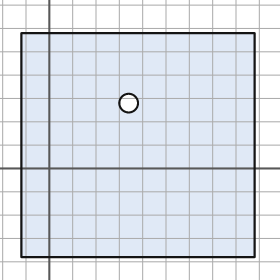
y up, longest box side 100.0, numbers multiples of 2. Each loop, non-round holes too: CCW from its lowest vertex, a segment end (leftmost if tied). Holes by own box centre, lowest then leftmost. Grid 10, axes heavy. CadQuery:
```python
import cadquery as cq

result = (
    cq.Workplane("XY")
    .moveTo(-12.0, -38.0)
    .lineTo(88.0, -38.0)
    .lineTo(88.0, 58.0)
    .lineTo(-12.0, 58.0)
    .close()
    .moveTo(34.0, 28.0)
    .circle(4.0)
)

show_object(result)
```